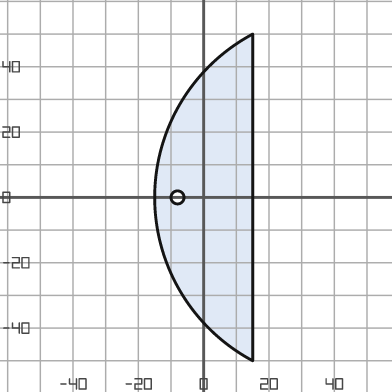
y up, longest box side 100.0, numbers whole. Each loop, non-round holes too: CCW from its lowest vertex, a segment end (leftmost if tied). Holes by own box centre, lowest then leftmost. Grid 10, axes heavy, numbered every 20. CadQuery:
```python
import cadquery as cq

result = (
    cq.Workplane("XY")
    .moveTo(15.0, -50.0)
    .lineTo(15.0, 50.0)
    .threePointArc((-15.0, 0.0), (15.0, -50.0))
    .close()
    .moveTo(-8.0, 0.0)
    .circle(2.0)
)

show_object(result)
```